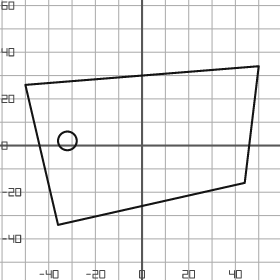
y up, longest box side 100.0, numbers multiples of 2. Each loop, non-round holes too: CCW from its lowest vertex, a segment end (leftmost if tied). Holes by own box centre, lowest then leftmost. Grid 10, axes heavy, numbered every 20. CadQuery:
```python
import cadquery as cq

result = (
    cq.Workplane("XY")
    .moveTo(-36.0, -34.0)
    .lineTo(44.0, -16.0)
    .lineTo(50.0, 34.0)
    .lineTo(-50.0, 26.0)
    .close()
    .moveTo(-32.0, 2.0)
    .circle(4.0)
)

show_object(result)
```